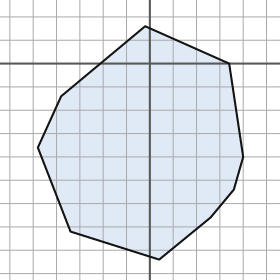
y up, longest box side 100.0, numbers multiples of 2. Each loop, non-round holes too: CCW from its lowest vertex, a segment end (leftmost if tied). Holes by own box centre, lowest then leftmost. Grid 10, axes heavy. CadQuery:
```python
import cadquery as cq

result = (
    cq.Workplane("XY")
    .moveTo(4.0, -84.0)
    .lineTo(26.0, -66.0)
    .lineTo(36.0, -54.0)
    .lineTo(40.0, -40.0)
    .lineTo(34.0, 0.0)
    .lineTo(-2.0, 16.0)
    .lineTo(-38.0, -14.0)
    .lineTo(-48.0, -36.0)
    .lineTo(-34.0, -72.0)
    .close()
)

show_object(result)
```